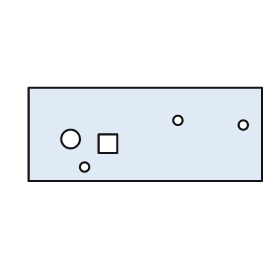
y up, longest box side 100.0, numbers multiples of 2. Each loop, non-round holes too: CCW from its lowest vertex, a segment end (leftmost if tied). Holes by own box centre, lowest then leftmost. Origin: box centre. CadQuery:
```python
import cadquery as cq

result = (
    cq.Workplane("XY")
    .moveTo(-50.0, -20.0)
    .lineTo(50.0, -20.0)
    .lineTo(50.0, 20.0)
    .lineTo(-50.0, 20.0)
    .close()
    .moveTo(-26.0, -14.0)
    .circle(2.0)
    .moveTo(-20.0, -8.0)
    .lineTo(-12.0, -8.0)
    .lineTo(-12.0, 0.0)
    .lineTo(-20.0, 0.0)
    .close()
    .moveTo(-32.0, -2.0)
    .circle(4.0)
    .moveTo(42.0, 4.0)
    .circle(2.0)
    .moveTo(14.0, 6.0)
    .circle(2.0)
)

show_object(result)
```